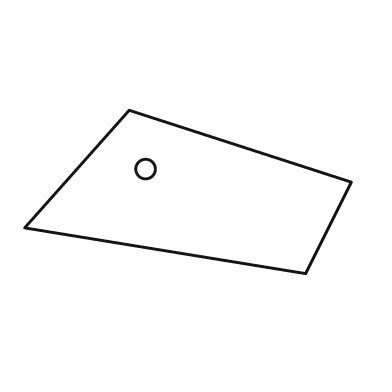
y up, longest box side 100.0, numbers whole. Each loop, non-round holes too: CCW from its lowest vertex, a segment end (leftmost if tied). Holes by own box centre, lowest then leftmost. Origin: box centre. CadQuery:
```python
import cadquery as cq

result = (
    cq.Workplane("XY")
    .moveTo(36.0, -25.0)
    .lineTo(50.0, 3.0)
    .lineTo(-18.0, 25.0)
    .lineTo(-50.0, -11.0)
    .close()
    .moveTo(-13.0, 7.0)
    .circle(3.0)
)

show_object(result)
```